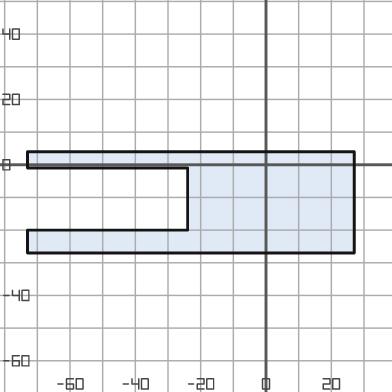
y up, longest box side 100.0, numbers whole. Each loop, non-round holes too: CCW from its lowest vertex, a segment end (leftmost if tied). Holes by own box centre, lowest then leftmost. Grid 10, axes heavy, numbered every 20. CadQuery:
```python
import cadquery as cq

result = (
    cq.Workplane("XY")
    .moveTo(-73.0, -27.0)
    .lineTo(27.0, -27.0)
    .lineTo(27.0, 4.0)
    .lineTo(-73.0, 4.0)
    .lineTo(-73.0, -1.0)
    .lineTo(-24.0, -1.0)
    .lineTo(-24.0, -20.0)
    .lineTo(-73.0, -20.0)
    .close()
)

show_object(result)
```